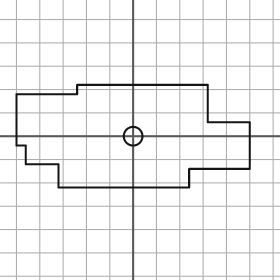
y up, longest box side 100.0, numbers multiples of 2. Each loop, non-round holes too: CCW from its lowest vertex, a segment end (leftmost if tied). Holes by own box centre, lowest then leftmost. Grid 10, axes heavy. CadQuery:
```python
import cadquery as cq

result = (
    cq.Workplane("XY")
    .moveTo(-32.0, -22.0)
    .lineTo(24.0, -22.0)
    .lineTo(24.0, -14.0)
    .lineTo(50.0, -14.0)
    .lineTo(50.0, 6.0)
    .lineTo(32.0, 6.0)
    .lineTo(32.0, 22.0)
    .lineTo(-24.0, 22.0)
    .lineTo(-24.0, 18.0)
    .lineTo(-50.0, 18.0)
    .lineTo(-50.0, -4.0)
    .lineTo(-46.0, -4.0)
    .lineTo(-46.0, -12.0)
    .lineTo(-32.0, -12.0)
    .close()
    .moveTo(0.0, 0.0)
    .circle(4.0)
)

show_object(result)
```